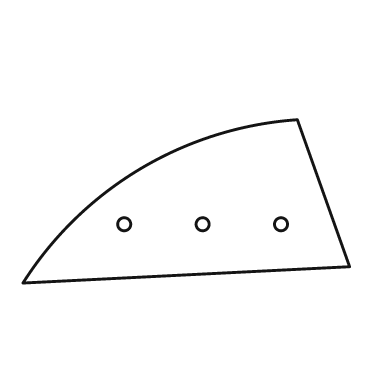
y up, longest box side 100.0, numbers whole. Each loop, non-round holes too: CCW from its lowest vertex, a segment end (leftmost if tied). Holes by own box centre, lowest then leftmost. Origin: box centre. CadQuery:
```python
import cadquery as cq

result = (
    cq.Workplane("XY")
    .moveTo(-50.0, -25.0)
    .lineTo(50.0, -20.0)
    .lineTo(34.0, 25.0)
    .threePointArc((-14.0, 10.0), (-50.0, -25.0))
    .close()
    .moveTo(-19.0, -7.0)
    .circle(2.0)
    .moveTo(5.0, -7.0)
    .circle(2.0)
    .moveTo(29.0, -7.0)
    .circle(2.0)
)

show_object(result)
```